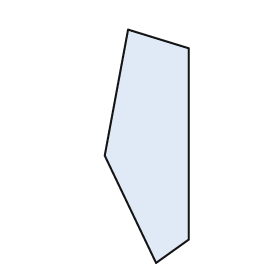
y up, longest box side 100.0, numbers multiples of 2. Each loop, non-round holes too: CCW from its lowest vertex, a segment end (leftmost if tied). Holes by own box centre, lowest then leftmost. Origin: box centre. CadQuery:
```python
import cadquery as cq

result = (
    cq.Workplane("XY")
    .moveTo(4.0, -50.0)
    .lineTo(18.0, -40.0)
    .lineTo(18.0, 42.0)
    .lineTo(-8.0, 50.0)
    .lineTo(-18.0, -4.0)
    .close()
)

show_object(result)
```